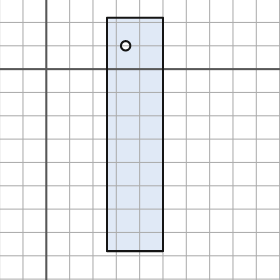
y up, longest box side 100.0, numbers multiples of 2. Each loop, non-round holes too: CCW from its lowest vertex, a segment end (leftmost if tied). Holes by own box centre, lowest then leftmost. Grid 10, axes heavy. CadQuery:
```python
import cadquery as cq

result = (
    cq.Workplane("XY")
    .moveTo(26.0, -78.0)
    .lineTo(50.0, -78.0)
    .lineTo(50.0, 22.0)
    .lineTo(26.0, 22.0)
    .close()
    .moveTo(34.0, 10.0)
    .circle(2.0)
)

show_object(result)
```